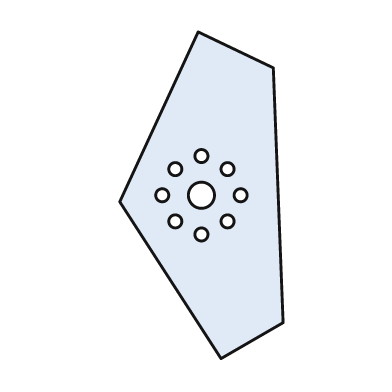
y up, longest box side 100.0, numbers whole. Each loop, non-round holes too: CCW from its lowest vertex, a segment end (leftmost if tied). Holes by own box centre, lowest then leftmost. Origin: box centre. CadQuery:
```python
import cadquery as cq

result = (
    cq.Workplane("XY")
    .moveTo(6.0, -50.0)
    .lineTo(25.0, -39.0)
    .lineTo(22.0, 39.0)
    .lineTo(-1.0, 50.0)
    .lineTo(-25.0, -2.0)
    .close()
    .moveTo(0.0, -12.0)
    .circle(2.0)
    .moveTo(-8.0, -8.0)
    .circle(2.0)
    .moveTo(8.0, -8.0)
    .circle(2.0)
    .moveTo(-12.0, 0.0)
    .circle(2.0)
    .moveTo(0.0, 0.0)
    .circle(4.0)
    .moveTo(12.0, 0.0)
    .circle(2.0)
    .moveTo(-8.0, 8.0)
    .circle(2.0)
    .moveTo(8.0, 8.0)
    .circle(2.0)
    .moveTo(0.0, 12.0)
    .circle(2.0)
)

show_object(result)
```